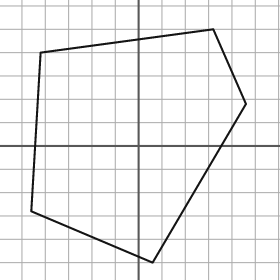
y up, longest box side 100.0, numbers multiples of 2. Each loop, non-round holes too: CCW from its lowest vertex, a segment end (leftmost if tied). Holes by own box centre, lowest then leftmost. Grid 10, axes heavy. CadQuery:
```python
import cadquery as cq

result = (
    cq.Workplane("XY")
    .moveTo(6.0, -50.0)
    .lineTo(46.0, 18.0)
    .lineTo(32.0, 50.0)
    .lineTo(-42.0, 40.0)
    .lineTo(-46.0, -28.0)
    .close()
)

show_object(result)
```